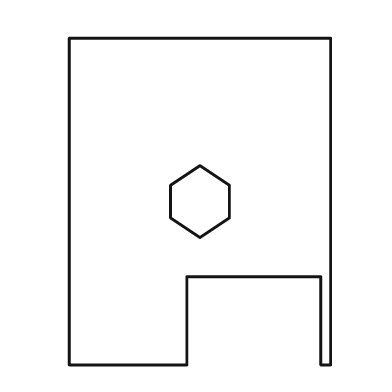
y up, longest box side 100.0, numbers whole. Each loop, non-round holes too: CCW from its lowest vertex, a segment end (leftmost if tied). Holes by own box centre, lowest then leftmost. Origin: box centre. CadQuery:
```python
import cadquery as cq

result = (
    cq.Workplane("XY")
    .moveTo(-40.0, -50.0)
    .lineTo(-4.0, -50.0)
    .lineTo(-4.0, -23.0)
    .lineTo(37.0, -23.0)
    .lineTo(37.0, -50.0)
    .lineTo(40.0, -50.0)
    .lineTo(40.0, 50.0)
    .lineTo(-40.0, 50.0)
    .close()
    .moveTo(0.0, -11.0)
    .lineTo(9.0, -5.0)
    .lineTo(9.0, 5.0)
    .lineTo(0.0, 11.0)
    .lineTo(-9.0, 5.0)
    .lineTo(-9.0, -5.0)
    .close()
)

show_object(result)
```